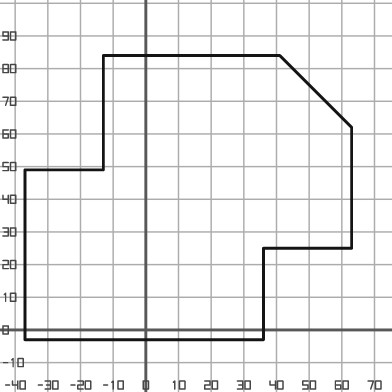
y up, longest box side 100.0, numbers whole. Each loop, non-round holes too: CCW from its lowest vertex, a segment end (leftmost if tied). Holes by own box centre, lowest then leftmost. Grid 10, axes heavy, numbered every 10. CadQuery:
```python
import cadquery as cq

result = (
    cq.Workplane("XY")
    .moveTo(-37.0, -3.0)
    .lineTo(36.0, -3.0)
    .lineTo(36.0, 25.0)
    .lineTo(63.0, 25.0)
    .lineTo(63.0, 62.0)
    .lineTo(41.0, 84.0)
    .lineTo(-13.0, 84.0)
    .lineTo(-13.0, 49.0)
    .lineTo(-37.0, 49.0)
    .close()
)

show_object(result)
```